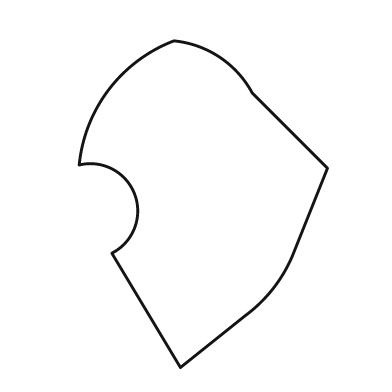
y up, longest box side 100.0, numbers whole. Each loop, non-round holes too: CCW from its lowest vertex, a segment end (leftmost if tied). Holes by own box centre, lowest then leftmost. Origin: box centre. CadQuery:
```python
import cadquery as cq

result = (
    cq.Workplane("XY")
    .moveTo(-7.0, -50.0)
    .lineTo(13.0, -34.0)
    .threePointArc((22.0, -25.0), (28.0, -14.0))
    .lineTo(38.0, 11.0)
    .lineTo(15.0, 34.0)
    .threePointArc((5.0, 45.0), (-9.0, 50.0))
    .threePointArc((-29.0, 35.0), (-38.0, 12.0))
    .threePointArc((-21.0, 3.0), (-28.0, -15.0))
    .close()
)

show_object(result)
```